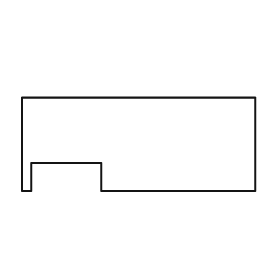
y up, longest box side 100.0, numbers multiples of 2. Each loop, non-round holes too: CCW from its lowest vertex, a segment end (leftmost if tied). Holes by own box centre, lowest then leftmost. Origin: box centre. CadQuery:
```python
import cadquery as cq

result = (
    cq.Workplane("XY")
    .moveTo(-50.0, -20.0)
    .lineTo(-46.0, -20.0)
    .lineTo(-46.0, -8.0)
    .lineTo(-16.0, -8.0)
    .lineTo(-16.0, -20.0)
    .lineTo(50.0, -20.0)
    .lineTo(50.0, 20.0)
    .lineTo(-50.0, 20.0)
    .close()
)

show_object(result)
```